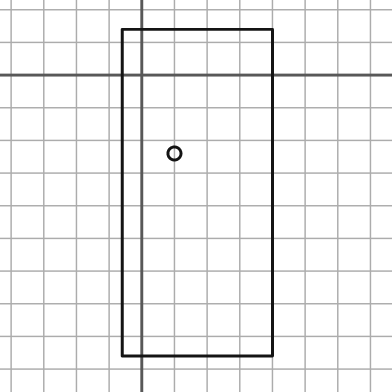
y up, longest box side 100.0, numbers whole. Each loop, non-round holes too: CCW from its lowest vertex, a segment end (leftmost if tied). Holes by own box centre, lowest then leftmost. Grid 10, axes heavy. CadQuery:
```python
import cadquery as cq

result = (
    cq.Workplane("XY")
    .moveTo(-6.0, -86.0)
    .lineTo(40.0, -86.0)
    .lineTo(40.0, 14.0)
    .lineTo(-6.0, 14.0)
    .close()
    .moveTo(10.0, -24.0)
    .circle(2.0)
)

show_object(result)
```